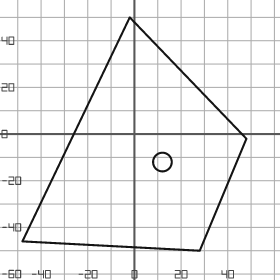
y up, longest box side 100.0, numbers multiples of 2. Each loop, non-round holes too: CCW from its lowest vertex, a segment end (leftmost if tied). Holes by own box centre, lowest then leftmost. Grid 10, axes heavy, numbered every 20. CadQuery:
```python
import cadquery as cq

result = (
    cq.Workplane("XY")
    .moveTo(28.0, -50.0)
    .lineTo(48.0, -2.0)
    .lineTo(-2.0, 50.0)
    .lineTo(-48.0, -46.0)
    .close()
    .moveTo(12.0, -12.0)
    .circle(4.0)
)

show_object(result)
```